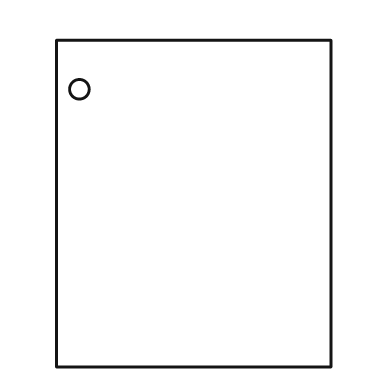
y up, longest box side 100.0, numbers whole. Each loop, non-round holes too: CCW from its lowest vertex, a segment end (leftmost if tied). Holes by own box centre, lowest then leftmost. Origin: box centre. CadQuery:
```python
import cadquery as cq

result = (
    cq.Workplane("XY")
    .moveTo(-42.0, -50.0)
    .lineTo(42.0, -50.0)
    .lineTo(42.0, 50.0)
    .lineTo(-42.0, 50.0)
    .close()
    .moveTo(-35.0, 35.0)
    .circle(3.0)
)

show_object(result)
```